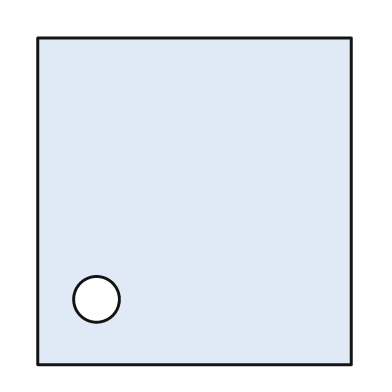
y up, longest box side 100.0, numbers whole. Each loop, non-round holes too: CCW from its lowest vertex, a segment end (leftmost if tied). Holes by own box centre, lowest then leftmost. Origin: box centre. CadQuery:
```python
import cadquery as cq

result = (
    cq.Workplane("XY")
    .moveTo(-48.0, -50.0)
    .lineTo(48.0, -50.0)
    .lineTo(48.0, 50.0)
    .lineTo(-48.0, 50.0)
    .close()
    .moveTo(-30.0, -30.0)
    .circle(7.0)
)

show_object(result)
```